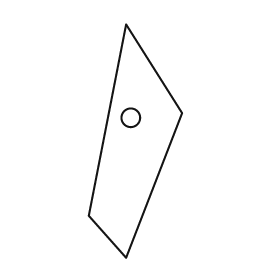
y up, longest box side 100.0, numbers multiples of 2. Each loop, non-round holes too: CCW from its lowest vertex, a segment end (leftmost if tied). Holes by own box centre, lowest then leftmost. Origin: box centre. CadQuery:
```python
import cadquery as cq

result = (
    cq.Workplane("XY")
    .moveTo(-4.0, -50.0)
    .lineTo(20.0, 12.0)
    .lineTo(-4.0, 50.0)
    .lineTo(-20.0, -32.0)
    .close()
    .moveTo(-2.0, 10.0)
    .circle(4.0)
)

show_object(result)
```